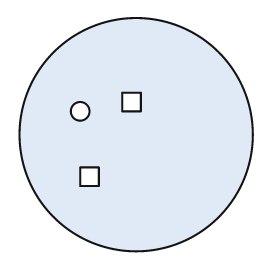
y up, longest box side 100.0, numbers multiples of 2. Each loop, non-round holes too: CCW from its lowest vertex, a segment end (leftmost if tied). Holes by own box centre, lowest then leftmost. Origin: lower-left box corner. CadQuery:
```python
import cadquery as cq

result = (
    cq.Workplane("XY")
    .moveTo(50.0, 50.0)
    .circle(50.0)
    .moveTo(26.0, 28.0)
    .lineTo(34.0, 28.0)
    .lineTo(34.0, 36.0)
    .lineTo(26.0, 36.0)
    .close()
    .moveTo(26.0, 60.0)
    .circle(4.0)
    .moveTo(44.0, 60.0)
    .lineTo(52.0, 60.0)
    .lineTo(52.0, 68.0)
    .lineTo(44.0, 68.0)
    .close()
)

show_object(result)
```